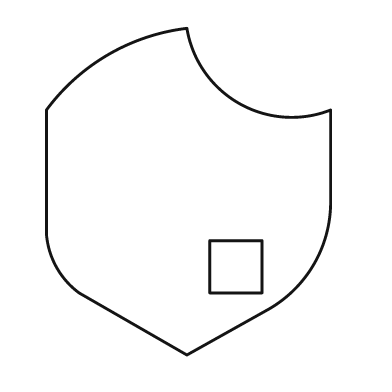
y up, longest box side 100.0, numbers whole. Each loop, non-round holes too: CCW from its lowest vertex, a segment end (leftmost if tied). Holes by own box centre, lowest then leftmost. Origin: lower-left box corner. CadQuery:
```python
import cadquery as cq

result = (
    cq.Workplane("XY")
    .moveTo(43.0, 0.0)
    .lineTo(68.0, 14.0)
    .threePointArc((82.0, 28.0), (87.0, 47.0))
    .lineTo(87.0, 75.0)
    .threePointArc((59.0, 77.0), (43.0, 100.0))
    .threePointArc((19.0, 92.0), (0.0, 75.0))
    .lineTo(0.0, 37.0)
    .threePointArc((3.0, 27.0), (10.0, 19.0))
    .close()
    .moveTo(50.0, 19.0)
    .lineTo(66.0, 19.0)
    .lineTo(66.0, 35.0)
    .lineTo(50.0, 35.0)
    .close()
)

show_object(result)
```